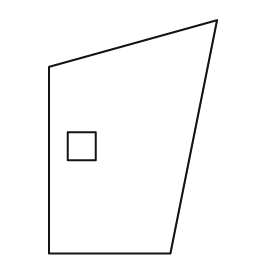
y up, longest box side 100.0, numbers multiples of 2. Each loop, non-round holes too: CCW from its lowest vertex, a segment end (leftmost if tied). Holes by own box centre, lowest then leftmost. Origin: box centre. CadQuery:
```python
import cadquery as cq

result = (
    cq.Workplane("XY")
    .moveTo(-36.0, -50.0)
    .lineTo(16.0, -50.0)
    .lineTo(36.0, 50.0)
    .lineTo(-36.0, 30.0)
    .close()
    .moveTo(-28.0, -10.0)
    .lineTo(-16.0, -10.0)
    .lineTo(-16.0, 2.0)
    .lineTo(-28.0, 2.0)
    .close()
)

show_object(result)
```